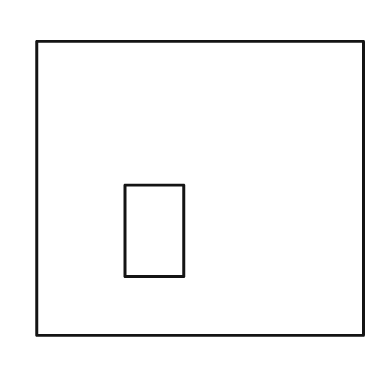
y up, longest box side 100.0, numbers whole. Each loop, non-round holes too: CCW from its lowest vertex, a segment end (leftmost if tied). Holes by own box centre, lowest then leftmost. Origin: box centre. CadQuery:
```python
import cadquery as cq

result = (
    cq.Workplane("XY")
    .moveTo(-50.0, -45.0)
    .lineTo(50.0, -45.0)
    .lineTo(50.0, 45.0)
    .lineTo(-50.0, 45.0)
    .close()
    .moveTo(-23.0, -27.0)
    .lineTo(-5.0, -27.0)
    .lineTo(-5.0, 1.0)
    .lineTo(-23.0, 1.0)
    .close()
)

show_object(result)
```